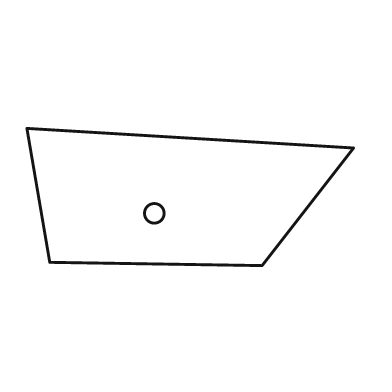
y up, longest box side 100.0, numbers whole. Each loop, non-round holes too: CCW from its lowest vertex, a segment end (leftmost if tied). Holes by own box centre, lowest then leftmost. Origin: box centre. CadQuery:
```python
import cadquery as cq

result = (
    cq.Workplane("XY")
    .moveTo(22.0, -21.0)
    .lineTo(50.0, 15.0)
    .lineTo(-50.0, 21.0)
    .lineTo(-43.0, -20.0)
    .close()
    .moveTo(-11.0, -5.0)
    .circle(3.0)
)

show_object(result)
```